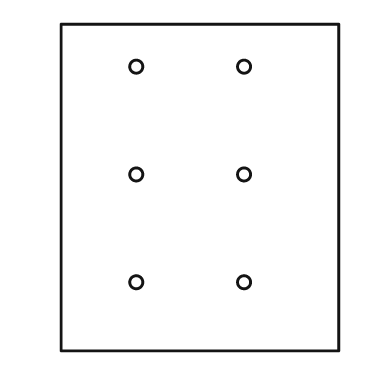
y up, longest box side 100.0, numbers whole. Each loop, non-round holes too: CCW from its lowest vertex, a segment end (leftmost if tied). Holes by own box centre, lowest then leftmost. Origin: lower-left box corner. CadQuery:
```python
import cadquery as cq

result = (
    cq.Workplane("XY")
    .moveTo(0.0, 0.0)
    .lineTo(85.0, 0.0)
    .lineTo(85.0, 100.0)
    .lineTo(0.0, 100.0)
    .close()
    .moveTo(23.0, 21.0)
    .circle(2.0)
    .moveTo(56.0, 21.0)
    .circle(2.0)
    .moveTo(23.0, 54.0)
    .circle(2.0)
    .moveTo(56.0, 54.0)
    .circle(2.0)
    .moveTo(23.0, 87.0)
    .circle(2.0)
    .moveTo(56.0, 87.0)
    .circle(2.0)
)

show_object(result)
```